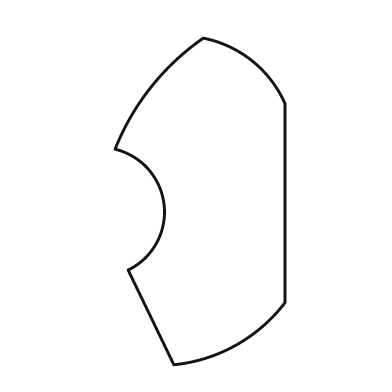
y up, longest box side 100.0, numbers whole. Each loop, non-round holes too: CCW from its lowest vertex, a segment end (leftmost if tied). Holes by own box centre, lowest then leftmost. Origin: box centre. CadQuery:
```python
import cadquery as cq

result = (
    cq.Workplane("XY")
    .moveTo(-8.0, -50.0)
    .threePointArc((11.0, -44.0), (26.0, -31.0))
    .lineTo(26.0, 30.0)
    .threePointArc((16.0, 43.0), (1.0, 50.0))
    .threePointArc((-15.0, 35.0), (-26.0, 16.0))
    .threePointArc((-11.0, -1.0), (-22.0, -21.0))
    .close()
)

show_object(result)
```